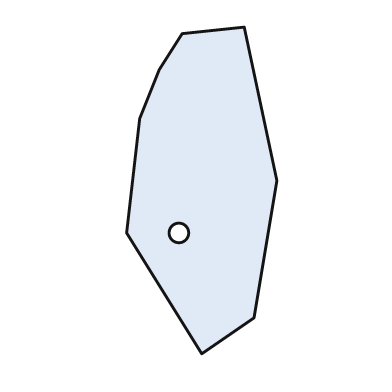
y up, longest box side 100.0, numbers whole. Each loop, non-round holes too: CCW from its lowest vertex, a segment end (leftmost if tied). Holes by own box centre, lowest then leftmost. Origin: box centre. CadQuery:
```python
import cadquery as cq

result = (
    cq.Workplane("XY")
    .moveTo(0.0, -50.0)
    .lineTo(16.0, -39.0)
    .lineTo(23.0, 3.0)
    .lineTo(13.0, 50.0)
    .lineTo(-6.0, 48.0)
    .lineTo(-13.0, 37.0)
    .lineTo(-19.0, 22.0)
    .lineTo(-23.0, -13.0)
    .close()
    .moveTo(-7.0, -13.0)
    .circle(3.0)
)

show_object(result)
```